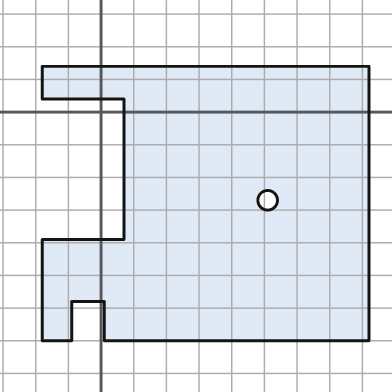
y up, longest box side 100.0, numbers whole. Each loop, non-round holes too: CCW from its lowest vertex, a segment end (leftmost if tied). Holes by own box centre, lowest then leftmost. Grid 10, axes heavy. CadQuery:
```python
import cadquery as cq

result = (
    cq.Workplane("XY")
    .moveTo(-18.0, -70.0)
    .lineTo(-9.0, -70.0)
    .lineTo(-9.0, -58.0)
    .lineTo(1.0, -58.0)
    .lineTo(1.0, -70.0)
    .lineTo(82.0, -70.0)
    .lineTo(82.0, 14.0)
    .lineTo(-18.0, 14.0)
    .lineTo(-18.0, 4.0)
    .lineTo(7.0, 4.0)
    .lineTo(7.0, -39.0)
    .lineTo(-18.0, -39.0)
    .close()
    .moveTo(51.0, -27.0)
    .circle(3.0)
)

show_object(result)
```